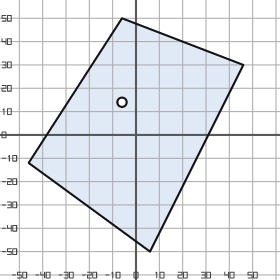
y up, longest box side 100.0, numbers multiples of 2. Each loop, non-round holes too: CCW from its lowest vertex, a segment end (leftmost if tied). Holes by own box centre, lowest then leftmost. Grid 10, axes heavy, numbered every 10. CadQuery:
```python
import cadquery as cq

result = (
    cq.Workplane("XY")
    .moveTo(6.0, -50.0)
    .lineTo(46.0, 30.0)
    .lineTo(-6.0, 50.0)
    .lineTo(-46.0, -12.0)
    .close()
    .moveTo(-6.0, 14.0)
    .circle(2.0)
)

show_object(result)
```